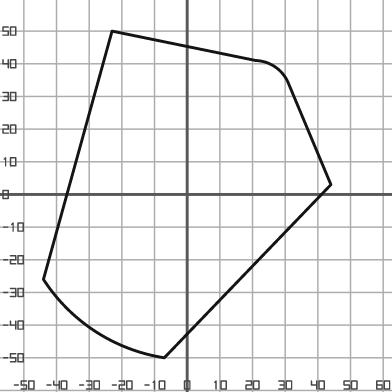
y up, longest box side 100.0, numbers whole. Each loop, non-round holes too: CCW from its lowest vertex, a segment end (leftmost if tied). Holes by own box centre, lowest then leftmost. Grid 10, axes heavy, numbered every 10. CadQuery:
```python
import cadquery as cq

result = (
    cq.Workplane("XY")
    .moveTo(-7.0, -50.0)
    .lineTo(44.0, 3.0)
    .lineTo(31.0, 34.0)
    .threePointArc((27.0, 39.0), (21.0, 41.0))
    .lineTo(-23.0, 50.0)
    .lineTo(-44.0, -26.0)
    .threePointArc((-28.0, -42.0), (-7.0, -50.0))
    .close()
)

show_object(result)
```